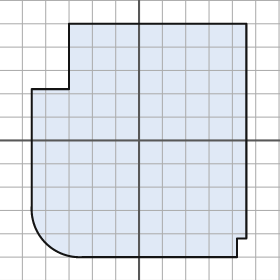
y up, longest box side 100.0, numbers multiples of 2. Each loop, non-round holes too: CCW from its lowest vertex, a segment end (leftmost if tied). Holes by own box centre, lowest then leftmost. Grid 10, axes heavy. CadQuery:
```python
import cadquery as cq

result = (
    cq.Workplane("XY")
    .moveTo(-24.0, -50.0)
    .lineTo(42.0, -50.0)
    .lineTo(42.0, -42.0)
    .lineTo(46.0, -42.0)
    .lineTo(46.0, 50.0)
    .lineTo(-30.0, 50.0)
    .lineTo(-30.0, 22.0)
    .lineTo(-46.0, 22.0)
    .lineTo(-46.0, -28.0)
    .threePointArc((-40.0, -44.0), (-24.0, -50.0))
    .close()
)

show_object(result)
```